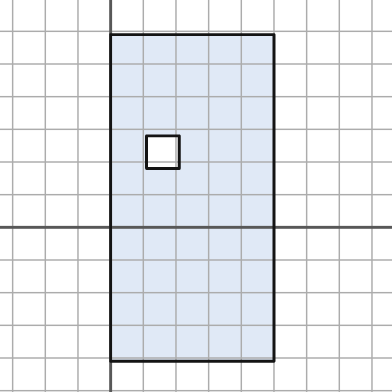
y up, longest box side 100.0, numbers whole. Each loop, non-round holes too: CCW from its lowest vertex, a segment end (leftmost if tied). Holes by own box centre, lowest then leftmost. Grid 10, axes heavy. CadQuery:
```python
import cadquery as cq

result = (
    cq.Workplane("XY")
    .moveTo(0.0, -41.0)
    .lineTo(50.0, -41.0)
    .lineTo(50.0, 59.0)
    .lineTo(0.0, 59.0)
    .close()
    .moveTo(11.0, 18.0)
    .lineTo(21.0, 18.0)
    .lineTo(21.0, 28.0)
    .lineTo(11.0, 28.0)
    .close()
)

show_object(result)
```